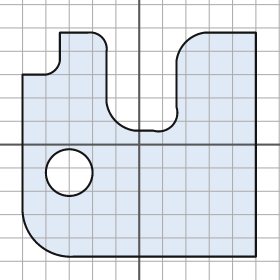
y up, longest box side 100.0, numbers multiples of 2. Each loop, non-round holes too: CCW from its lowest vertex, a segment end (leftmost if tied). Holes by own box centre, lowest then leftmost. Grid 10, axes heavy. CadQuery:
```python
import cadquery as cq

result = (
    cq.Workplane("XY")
    .moveTo(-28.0, -48.0)
    .lineTo(50.0, -48.0)
    .lineTo(50.0, 48.0)
    .lineTo(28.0, 48.0)
    .threePointArc((20.0, 44.0), (16.0, 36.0))
    .lineTo(16.0, 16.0)
    .threePointArc((14.0, 8.0), (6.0, 6.0))
    .lineTo(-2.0, 6.0)
    .threePointArc((-10.0, 10.0), (-14.0, 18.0))
    .lineTo(-14.0, 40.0)
    .threePointArc((-16.0, 46.0), (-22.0, 48.0))
    .lineTo(-34.0, 48.0)
    .lineTo(-34.0, 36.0)
    .threePointArc((-36.0, 32.0), (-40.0, 30.0))
    .lineTo(-50.0, 30.0)
    .lineTo(-50.0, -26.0)
    .threePointArc((-44.0, -42.0), (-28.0, -48.0))
    .close()
    .moveTo(-30.0, -12.0)
    .circle(10.0)
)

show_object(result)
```